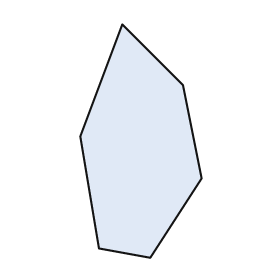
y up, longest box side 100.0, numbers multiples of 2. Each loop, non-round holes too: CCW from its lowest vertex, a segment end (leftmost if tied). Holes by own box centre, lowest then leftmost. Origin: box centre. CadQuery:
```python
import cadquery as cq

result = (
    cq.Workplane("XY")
    .moveTo(4.0, -50.0)
    .lineTo(26.0, -16.0)
    .lineTo(18.0, 24.0)
    .lineTo(-8.0, 50.0)
    .lineTo(-26.0, 2.0)
    .lineTo(-18.0, -46.0)
    .close()
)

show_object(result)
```